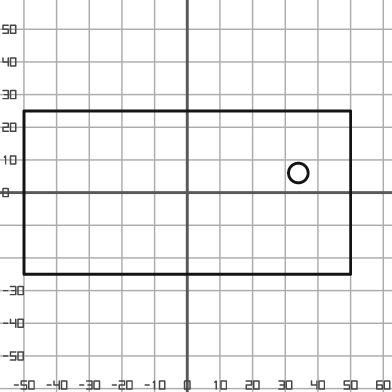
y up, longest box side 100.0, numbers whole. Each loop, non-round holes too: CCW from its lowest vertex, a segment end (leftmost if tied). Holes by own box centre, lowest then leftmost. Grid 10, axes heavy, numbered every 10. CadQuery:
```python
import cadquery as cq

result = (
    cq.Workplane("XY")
    .moveTo(-50.0, -25.0)
    .lineTo(50.0, -25.0)
    .lineTo(50.0, 25.0)
    .lineTo(-50.0, 25.0)
    .close()
    .moveTo(34.0, 6.0)
    .circle(3.0)
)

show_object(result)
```